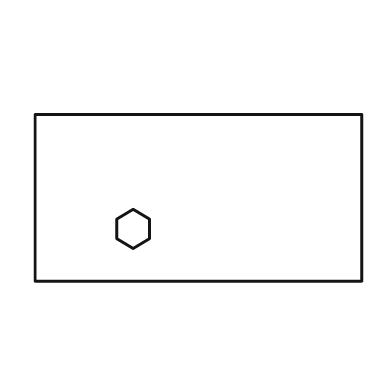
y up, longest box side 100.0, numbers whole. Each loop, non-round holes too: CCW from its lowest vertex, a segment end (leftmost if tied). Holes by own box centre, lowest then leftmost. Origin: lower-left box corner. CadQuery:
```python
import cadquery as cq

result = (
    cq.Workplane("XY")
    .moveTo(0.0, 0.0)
    .lineTo(100.0, 0.0)
    .lineTo(100.0, 51.0)
    .lineTo(0.0, 51.0)
    .close()
    .moveTo(30.0, 10.0)
    .lineTo(35.0, 13.0)
    .lineTo(35.0, 19.0)
    .lineTo(30.0, 22.0)
    .lineTo(25.0, 19.0)
    .lineTo(25.0, 13.0)
    .close()
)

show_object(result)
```